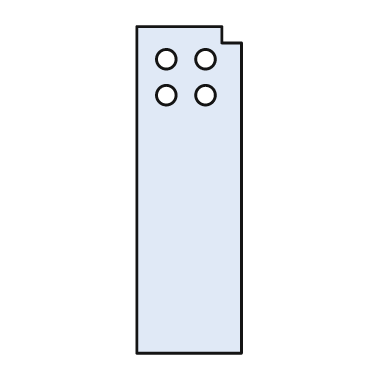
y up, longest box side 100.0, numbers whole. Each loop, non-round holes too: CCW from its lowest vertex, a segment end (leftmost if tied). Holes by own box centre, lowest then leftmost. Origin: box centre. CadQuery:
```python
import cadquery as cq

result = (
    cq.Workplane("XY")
    .moveTo(-16.0, -50.0)
    .lineTo(16.0, -50.0)
    .lineTo(16.0, 45.0)
    .lineTo(10.0, 45.0)
    .lineTo(10.0, 50.0)
    .lineTo(-16.0, 50.0)
    .close()
    .moveTo(-7.0, 29.0)
    .circle(3.0)
    .moveTo(5.0, 29.0)
    .circle(3.0)
    .moveTo(-7.0, 40.0)
    .circle(3.0)
    .moveTo(5.0, 40.0)
    .circle(3.0)
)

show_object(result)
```